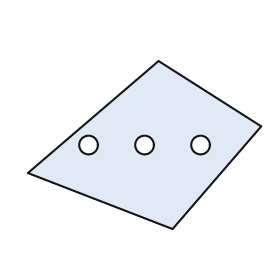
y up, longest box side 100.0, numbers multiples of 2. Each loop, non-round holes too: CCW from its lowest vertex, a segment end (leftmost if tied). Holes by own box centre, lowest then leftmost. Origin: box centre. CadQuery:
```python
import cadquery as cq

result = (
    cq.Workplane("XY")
    .moveTo(12.0, -36.0)
    .lineTo(50.0, 8.0)
    .lineTo(6.0, 36.0)
    .lineTo(-50.0, -12.0)
    .close()
    .moveTo(-24.0, 0.0)
    .circle(4.0)
    .moveTo(0.0, 0.0)
    .circle(4.0)
    .moveTo(24.0, 0.0)
    .circle(4.0)
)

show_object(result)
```